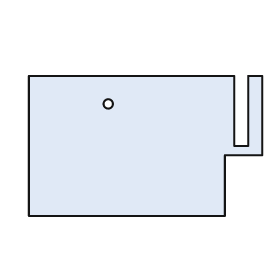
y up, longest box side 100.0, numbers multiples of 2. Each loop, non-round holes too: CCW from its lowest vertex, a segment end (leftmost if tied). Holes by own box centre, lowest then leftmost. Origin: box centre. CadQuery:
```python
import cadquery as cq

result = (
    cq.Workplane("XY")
    .moveTo(-50.0, -30.0)
    .lineTo(34.0, -30.0)
    .lineTo(34.0, -4.0)
    .lineTo(50.0, -4.0)
    .lineTo(50.0, 30.0)
    .lineTo(44.0, 30.0)
    .lineTo(44.0, 0.0)
    .lineTo(38.0, 0.0)
    .lineTo(38.0, 30.0)
    .lineTo(-50.0, 30.0)
    .close()
    .moveTo(-16.0, 18.0)
    .circle(2.0)
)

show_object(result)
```